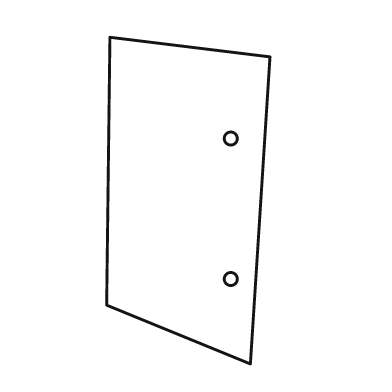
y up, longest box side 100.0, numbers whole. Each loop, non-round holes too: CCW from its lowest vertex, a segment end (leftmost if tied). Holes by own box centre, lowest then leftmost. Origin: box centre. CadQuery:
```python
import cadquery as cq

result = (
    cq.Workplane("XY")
    .moveTo(19.0, -50.0)
    .lineTo(25.0, 44.0)
    .lineTo(-24.0, 50.0)
    .lineTo(-25.0, -32.0)
    .close()
    .moveTo(13.0, -24.0)
    .circle(2.0)
    .moveTo(13.0, 19.0)
    .circle(2.0)
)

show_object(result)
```